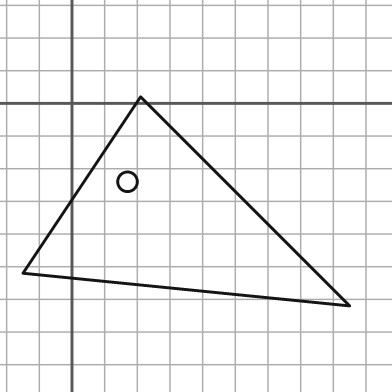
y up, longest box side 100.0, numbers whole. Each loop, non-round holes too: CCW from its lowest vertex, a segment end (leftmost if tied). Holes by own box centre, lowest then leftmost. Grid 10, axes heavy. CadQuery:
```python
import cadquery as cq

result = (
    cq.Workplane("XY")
    .moveTo(85.0, -62.0)
    .lineTo(21.0, 2.0)
    .lineTo(-15.0, -52.0)
    .close()
    .moveTo(17.0, -24.0)
    .circle(3.0)
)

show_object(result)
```